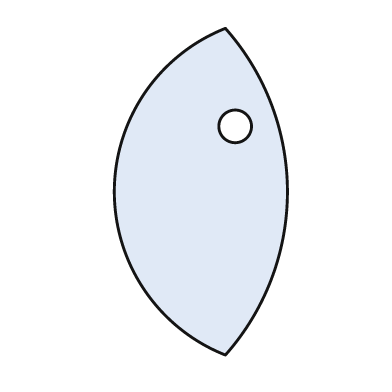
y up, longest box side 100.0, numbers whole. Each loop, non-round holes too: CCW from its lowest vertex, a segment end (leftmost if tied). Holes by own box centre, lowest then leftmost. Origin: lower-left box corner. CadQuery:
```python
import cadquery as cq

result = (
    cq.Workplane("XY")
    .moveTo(34.0, 0.0)
    .threePointArc((53.0, 50.0), (34.0, 100.0))
    .threePointArc((0.0, 50.0), (34.0, 0.0))
    .close()
    .moveTo(37.0, 70.0)
    .circle(5.0)
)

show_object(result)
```